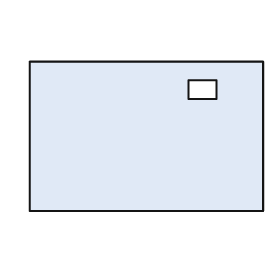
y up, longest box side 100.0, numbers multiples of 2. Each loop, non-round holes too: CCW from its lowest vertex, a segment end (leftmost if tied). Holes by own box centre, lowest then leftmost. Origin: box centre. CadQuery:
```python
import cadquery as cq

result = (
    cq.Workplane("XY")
    .moveTo(-50.0, -32.0)
    .lineTo(50.0, -32.0)
    .lineTo(50.0, 32.0)
    .lineTo(-50.0, 32.0)
    .close()
    .moveTo(18.0, 16.0)
    .lineTo(30.0, 16.0)
    .lineTo(30.0, 24.0)
    .lineTo(18.0, 24.0)
    .close()
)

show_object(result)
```